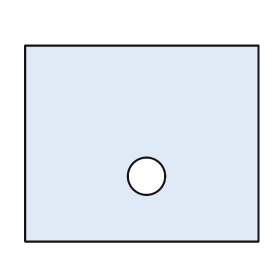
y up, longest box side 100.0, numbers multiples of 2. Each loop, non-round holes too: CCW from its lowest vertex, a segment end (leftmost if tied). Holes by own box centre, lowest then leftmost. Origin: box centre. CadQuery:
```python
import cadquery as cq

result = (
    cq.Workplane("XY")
    .moveTo(-50.0, -42.0)
    .lineTo(50.0, -42.0)
    .lineTo(50.0, 42.0)
    .lineTo(-50.0, 42.0)
    .close()
    .moveTo(2.0, -14.0)
    .circle(8.0)
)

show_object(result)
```